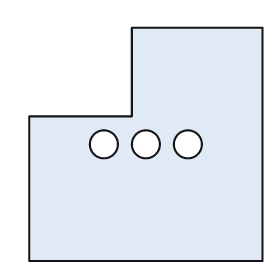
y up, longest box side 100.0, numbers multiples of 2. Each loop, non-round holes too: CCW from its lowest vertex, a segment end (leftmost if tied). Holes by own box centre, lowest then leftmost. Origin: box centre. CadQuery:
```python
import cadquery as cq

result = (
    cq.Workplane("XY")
    .moveTo(-50.0, -50.0)
    .lineTo(50.0, -50.0)
    .lineTo(50.0, 50.0)
    .lineTo(-6.0, 50.0)
    .lineTo(-6.0, 12.0)
    .lineTo(-50.0, 12.0)
    .close()
    .moveTo(-18.0, 0.0)
    .circle(6.0)
    .moveTo(0.0, 0.0)
    .circle(6.0)
    .moveTo(18.0, 0.0)
    .circle(6.0)
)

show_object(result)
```